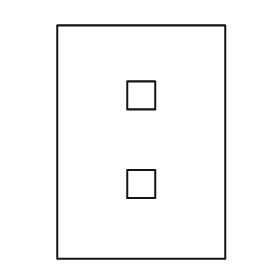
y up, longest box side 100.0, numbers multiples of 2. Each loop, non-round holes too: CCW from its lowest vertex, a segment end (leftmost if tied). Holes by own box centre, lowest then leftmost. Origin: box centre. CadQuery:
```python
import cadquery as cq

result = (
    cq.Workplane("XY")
    .moveTo(-36.0, -50.0)
    .lineTo(36.0, -50.0)
    .lineTo(36.0, 50.0)
    .lineTo(-36.0, 50.0)
    .close()
    .moveTo(-6.0, -24.0)
    .lineTo(6.0, -24.0)
    .lineTo(6.0, -12.0)
    .lineTo(-6.0, -12.0)
    .close()
    .moveTo(-6.0, 14.0)
    .lineTo(6.0, 14.0)
    .lineTo(6.0, 26.0)
    .lineTo(-6.0, 26.0)
    .close()
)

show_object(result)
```